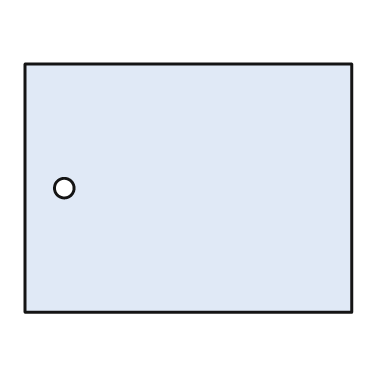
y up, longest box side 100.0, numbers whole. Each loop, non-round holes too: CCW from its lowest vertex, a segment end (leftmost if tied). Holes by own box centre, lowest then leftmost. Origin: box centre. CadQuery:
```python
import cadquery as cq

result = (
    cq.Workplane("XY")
    .moveTo(-50.0, -38.0)
    .lineTo(50.0, -38.0)
    .lineTo(50.0, 38.0)
    .lineTo(-50.0, 38.0)
    .close()
    .moveTo(-38.0, 0.0)
    .circle(3.0)
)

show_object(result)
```